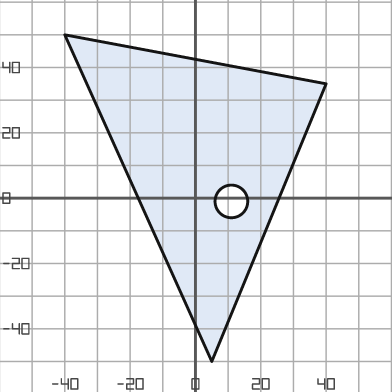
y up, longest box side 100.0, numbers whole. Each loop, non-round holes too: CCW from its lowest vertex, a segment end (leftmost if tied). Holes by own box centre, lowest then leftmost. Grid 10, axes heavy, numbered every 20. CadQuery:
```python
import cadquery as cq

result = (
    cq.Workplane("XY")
    .moveTo(5.0, -50.0)
    .lineTo(40.0, 35.0)
    .lineTo(-40.0, 50.0)
    .close()
    .moveTo(11.0, -1.0)
    .circle(5.0)
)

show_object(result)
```